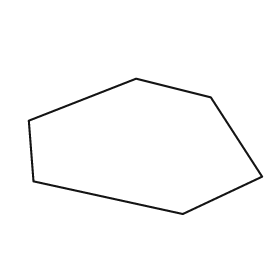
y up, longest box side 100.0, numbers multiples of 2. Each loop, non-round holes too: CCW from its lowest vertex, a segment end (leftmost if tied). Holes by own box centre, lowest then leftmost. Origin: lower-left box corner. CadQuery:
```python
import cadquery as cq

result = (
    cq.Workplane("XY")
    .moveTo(66.0, 0.0)
    .lineTo(100.0, 16.0)
    .lineTo(78.0, 50.0)
    .lineTo(46.0, 58.0)
    .lineTo(0.0, 40.0)
    .lineTo(2.0, 14.0)
    .close()
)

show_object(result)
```